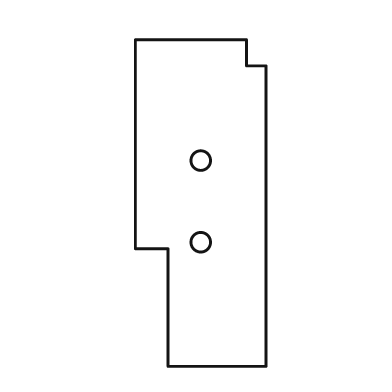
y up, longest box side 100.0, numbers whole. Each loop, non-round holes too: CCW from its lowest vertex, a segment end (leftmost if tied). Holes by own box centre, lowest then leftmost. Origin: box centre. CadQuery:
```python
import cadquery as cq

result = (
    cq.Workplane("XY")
    .moveTo(-10.0, -50.0)
    .lineTo(20.0, -50.0)
    .lineTo(20.0, 42.0)
    .lineTo(14.0, 42.0)
    .lineTo(14.0, 50.0)
    .lineTo(-20.0, 50.0)
    .lineTo(-20.0, -14.0)
    .lineTo(-10.0, -14.0)
    .close()
    .moveTo(0.0, -12.0)
    .circle(3.0)
    .moveTo(0.0, 13.0)
    .circle(3.0)
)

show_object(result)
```